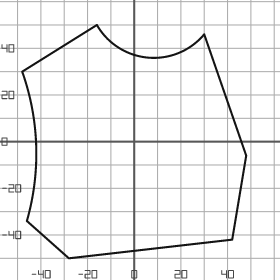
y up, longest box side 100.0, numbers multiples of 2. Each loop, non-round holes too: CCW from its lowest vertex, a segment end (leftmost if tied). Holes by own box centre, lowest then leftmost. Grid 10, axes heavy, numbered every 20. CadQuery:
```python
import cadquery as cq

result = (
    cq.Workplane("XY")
    .moveTo(-28.0, -50.0)
    .lineTo(42.0, -42.0)
    .lineTo(48.0, -6.0)
    .lineTo(30.0, 46.0)
    .threePointArc((6.0, 36.0), (-16.0, 50.0))
    .lineTo(-48.0, 30.0)
    .threePointArc((-42.0, -2.0), (-46.0, -34.0))
    .close()
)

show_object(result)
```